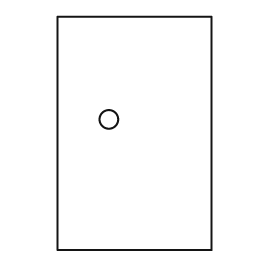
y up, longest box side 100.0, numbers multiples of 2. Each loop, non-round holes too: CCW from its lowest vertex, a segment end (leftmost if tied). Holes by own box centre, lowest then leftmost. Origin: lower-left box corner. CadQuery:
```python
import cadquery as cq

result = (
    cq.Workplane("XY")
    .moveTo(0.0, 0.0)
    .lineTo(66.0, 0.0)
    .lineTo(66.0, 100.0)
    .lineTo(0.0, 100.0)
    .close()
    .moveTo(22.0, 56.0)
    .circle(4.0)
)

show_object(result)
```